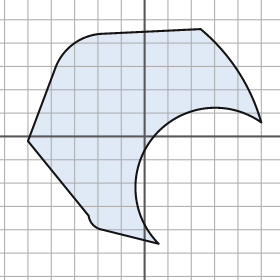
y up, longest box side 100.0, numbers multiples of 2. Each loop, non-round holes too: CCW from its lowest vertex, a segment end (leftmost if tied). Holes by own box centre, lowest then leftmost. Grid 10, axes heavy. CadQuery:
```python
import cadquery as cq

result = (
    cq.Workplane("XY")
    .moveTo(6.0, -46.0)
    .threePointArc((4.0, 0.0), (50.0, 6.0))
    .threePointArc((40.0, 28.0), (24.0, 46.0))
    .lineTo(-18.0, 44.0)
    .threePointArc((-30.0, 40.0), (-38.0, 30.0))
    .lineTo(-50.0, -2.0)
    .lineTo(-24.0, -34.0)
    .threePointArc((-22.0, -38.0), (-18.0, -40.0))
    .close()
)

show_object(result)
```